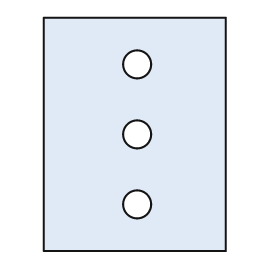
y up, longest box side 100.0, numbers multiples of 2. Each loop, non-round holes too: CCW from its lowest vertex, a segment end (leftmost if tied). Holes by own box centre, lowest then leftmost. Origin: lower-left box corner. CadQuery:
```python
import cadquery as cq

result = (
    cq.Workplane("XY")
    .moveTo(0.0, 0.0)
    .lineTo(78.0, 0.0)
    .lineTo(78.0, 100.0)
    .lineTo(0.0, 100.0)
    .close()
    .moveTo(40.0, 20.0)
    .circle(6.0)
    .moveTo(40.0, 50.0)
    .circle(6.0)
    .moveTo(40.0, 80.0)
    .circle(6.0)
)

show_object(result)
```